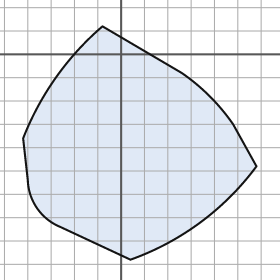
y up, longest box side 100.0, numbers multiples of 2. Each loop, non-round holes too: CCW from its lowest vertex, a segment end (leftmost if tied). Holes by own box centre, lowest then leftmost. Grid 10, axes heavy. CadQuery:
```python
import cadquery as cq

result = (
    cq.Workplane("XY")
    .moveTo(4.0, -88.0)
    .threePointArc((34.0, -72.0), (58.0, -48.0))
    .lineTo(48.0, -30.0)
    .threePointArc((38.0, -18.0), (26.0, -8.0))
    .lineTo(-8.0, 12.0)
    .threePointArc((-28.0, -10.0), (-42.0, -36.0))
    .lineTo(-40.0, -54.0)
    .threePointArc((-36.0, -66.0), (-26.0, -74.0))
    .close()
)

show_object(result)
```